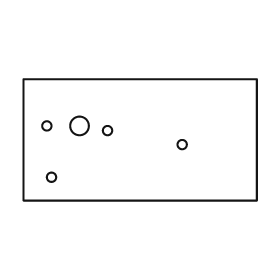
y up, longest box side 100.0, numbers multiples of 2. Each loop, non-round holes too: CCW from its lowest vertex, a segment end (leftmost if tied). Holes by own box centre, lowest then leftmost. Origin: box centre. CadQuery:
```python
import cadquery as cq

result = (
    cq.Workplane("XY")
    .moveTo(-50.0, -26.0)
    .lineTo(50.0, -26.0)
    .lineTo(50.0, 26.0)
    .lineTo(-50.0, 26.0)
    .close()
    .moveTo(-38.0, -16.0)
    .circle(2.0)
    .moveTo(18.0, -2.0)
    .circle(2.0)
    .moveTo(-14.0, 4.0)
    .circle(2.0)
    .moveTo(-40.0, 6.0)
    .circle(2.0)
    .moveTo(-26.0, 6.0)
    .circle(4.0)
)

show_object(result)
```